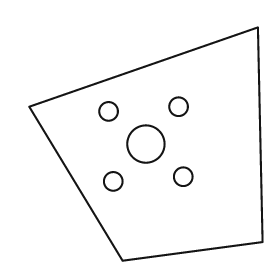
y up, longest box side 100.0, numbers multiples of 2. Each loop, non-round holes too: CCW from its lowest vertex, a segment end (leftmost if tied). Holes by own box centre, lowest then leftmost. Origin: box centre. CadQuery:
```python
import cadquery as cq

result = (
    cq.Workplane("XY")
    .moveTo(-10.0, -50.0)
    .lineTo(50.0, -42.0)
    .lineTo(48.0, 50.0)
    .lineTo(-50.0, 16.0)
    .close()
    .moveTo(-14.0, -16.0)
    .circle(4.0)
    .moveTo(16.0, -14.0)
    .circle(4.0)
    .moveTo(0.0, 0.0)
    .circle(8.0)
    .moveTo(-16.0, 14.0)
    .circle(4.0)
    .moveTo(14.0, 16.0)
    .circle(4.0)
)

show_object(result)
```